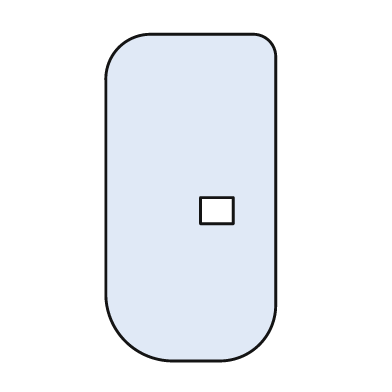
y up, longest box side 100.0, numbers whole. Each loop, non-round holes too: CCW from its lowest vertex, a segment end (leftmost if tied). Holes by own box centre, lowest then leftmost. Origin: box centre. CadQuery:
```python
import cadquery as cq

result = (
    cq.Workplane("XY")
    .moveTo(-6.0, -50.0)
    .lineTo(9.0, -50.0)
    .threePointArc((21.0, -45.0), (26.0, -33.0))
    .lineTo(26.0, 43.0)
    .threePointArc((24.0, 48.0), (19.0, 50.0))
    .lineTo(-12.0, 50.0)
    .threePointArc((-22.0, 46.0), (-26.0, 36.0))
    .lineTo(-26.0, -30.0)
    .threePointArc((-20.0, -44.0), (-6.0, -50.0))
    .close()
    .moveTo(3.0, -8.0)
    .lineTo(13.0, -8.0)
    .lineTo(13.0, 0.0)
    .lineTo(3.0, 0.0)
    .close()
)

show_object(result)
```